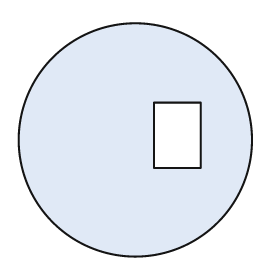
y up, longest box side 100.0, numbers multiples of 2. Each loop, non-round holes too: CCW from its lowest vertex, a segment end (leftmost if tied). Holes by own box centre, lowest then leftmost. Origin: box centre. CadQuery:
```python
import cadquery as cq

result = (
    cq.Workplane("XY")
    .moveTo(0.0, 0.0)
    .circle(50.0)
    .moveTo(8.0, -12.0)
    .lineTo(28.0, -12.0)
    .lineTo(28.0, 16.0)
    .lineTo(8.0, 16.0)
    .close()
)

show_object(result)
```